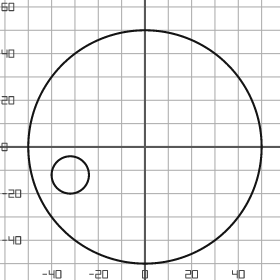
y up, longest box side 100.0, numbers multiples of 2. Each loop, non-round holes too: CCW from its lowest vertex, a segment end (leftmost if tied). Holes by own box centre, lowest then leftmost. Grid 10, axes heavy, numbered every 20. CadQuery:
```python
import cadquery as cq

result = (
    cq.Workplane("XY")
    .moveTo(0.0, 0.0)
    .circle(50.0)
    .moveTo(-32.0, -12.0)
    .circle(8.0)
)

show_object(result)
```